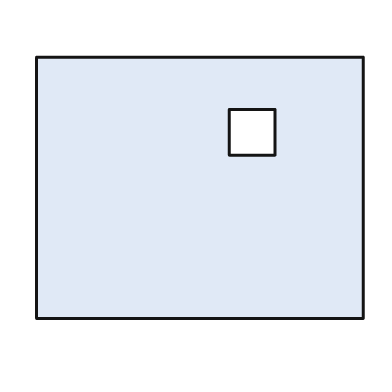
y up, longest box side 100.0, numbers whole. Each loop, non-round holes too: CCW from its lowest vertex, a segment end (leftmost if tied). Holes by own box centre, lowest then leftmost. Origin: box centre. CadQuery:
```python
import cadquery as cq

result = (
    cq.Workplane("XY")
    .moveTo(-50.0, -40.0)
    .lineTo(50.0, -40.0)
    .lineTo(50.0, 40.0)
    .lineTo(-50.0, 40.0)
    .close()
    .moveTo(9.0, 10.0)
    .lineTo(23.0, 10.0)
    .lineTo(23.0, 24.0)
    .lineTo(9.0, 24.0)
    .close()
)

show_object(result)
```